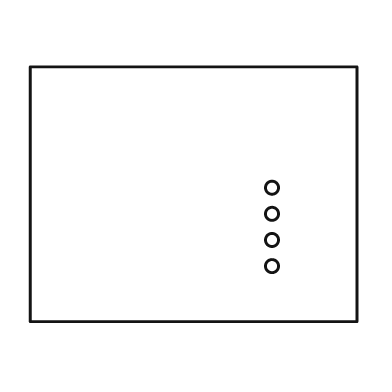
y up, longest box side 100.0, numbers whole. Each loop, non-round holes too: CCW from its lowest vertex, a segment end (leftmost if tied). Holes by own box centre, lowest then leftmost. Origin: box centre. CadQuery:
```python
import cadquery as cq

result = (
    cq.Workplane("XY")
    .moveTo(-50.0, -39.0)
    .lineTo(50.0, -39.0)
    .lineTo(50.0, 39.0)
    .lineTo(-50.0, 39.0)
    .close()
    .moveTo(24.0, -22.0)
    .circle(2.0)
    .moveTo(24.0, -14.0)
    .circle(2.0)
    .moveTo(24.0, -6.0)
    .circle(2.0)
    .moveTo(24.0, 2.0)
    .circle(2.0)
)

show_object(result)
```